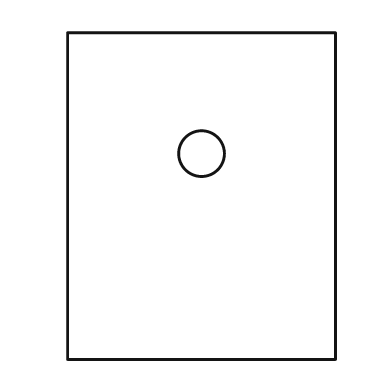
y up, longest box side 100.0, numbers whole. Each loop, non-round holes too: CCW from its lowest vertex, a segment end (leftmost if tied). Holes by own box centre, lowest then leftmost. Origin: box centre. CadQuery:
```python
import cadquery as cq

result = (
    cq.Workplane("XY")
    .moveTo(-41.0, -50.0)
    .lineTo(41.0, -50.0)
    .lineTo(41.0, 50.0)
    .lineTo(-41.0, 50.0)
    .close()
    .moveTo(0.0, 13.0)
    .circle(7.0)
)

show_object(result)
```